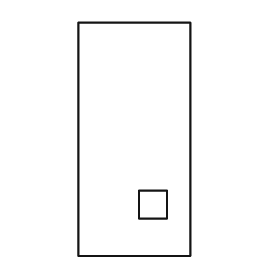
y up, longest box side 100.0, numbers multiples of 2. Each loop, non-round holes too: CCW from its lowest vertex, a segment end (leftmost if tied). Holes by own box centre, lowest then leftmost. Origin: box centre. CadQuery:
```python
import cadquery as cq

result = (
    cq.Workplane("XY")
    .moveTo(-24.0, -50.0)
    .lineTo(24.0, -50.0)
    .lineTo(24.0, 50.0)
    .lineTo(-24.0, 50.0)
    .close()
    .moveTo(2.0, -34.0)
    .lineTo(14.0, -34.0)
    .lineTo(14.0, -22.0)
    .lineTo(2.0, -22.0)
    .close()
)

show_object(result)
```